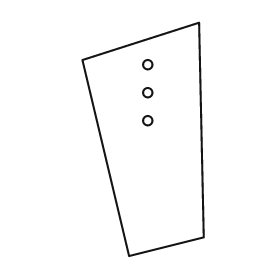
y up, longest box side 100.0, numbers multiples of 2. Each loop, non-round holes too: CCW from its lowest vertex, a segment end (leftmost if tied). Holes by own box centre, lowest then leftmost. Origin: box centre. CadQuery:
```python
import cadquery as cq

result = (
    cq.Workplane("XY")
    .moveTo(-6.0, -50.0)
    .lineTo(26.0, -42.0)
    .lineTo(24.0, 50.0)
    .lineTo(-26.0, 34.0)
    .close()
    .moveTo(2.0, 8.0)
    .circle(2.0)
    .moveTo(2.0, 20.0)
    .circle(2.0)
    .moveTo(2.0, 32.0)
    .circle(2.0)
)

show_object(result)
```